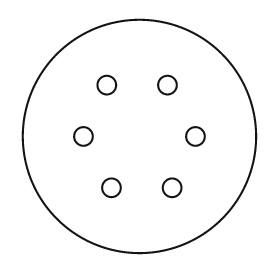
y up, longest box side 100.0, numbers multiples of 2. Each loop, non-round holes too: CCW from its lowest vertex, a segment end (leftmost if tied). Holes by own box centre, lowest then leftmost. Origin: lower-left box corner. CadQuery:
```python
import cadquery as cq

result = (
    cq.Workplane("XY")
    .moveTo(50.0, 50.0)
    .circle(50.0)
    .moveTo(38.0, 28.0)
    .circle(4.0)
    .moveTo(64.0, 28.0)
    .circle(4.0)
    .moveTo(26.0, 50.0)
    .circle(4.0)
    .moveTo(74.0, 50.0)
    .circle(4.0)
    .moveTo(36.0, 72.0)
    .circle(4.0)
    .moveTo(62.0, 72.0)
    .circle(4.0)
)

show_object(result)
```